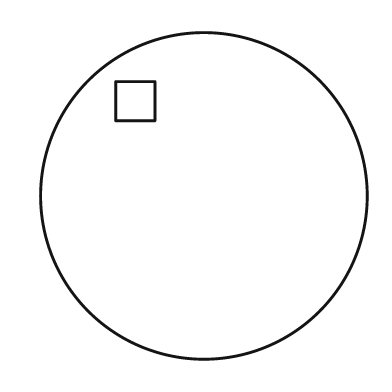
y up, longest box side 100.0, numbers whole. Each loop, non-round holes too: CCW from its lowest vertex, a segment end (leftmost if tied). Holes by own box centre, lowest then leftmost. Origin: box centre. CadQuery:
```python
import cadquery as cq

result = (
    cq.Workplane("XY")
    .moveTo(0.0, 0.0)
    .circle(50.0)
    .moveTo(-27.0, 23.0)
    .lineTo(-15.0, 23.0)
    .lineTo(-15.0, 35.0)
    .lineTo(-27.0, 35.0)
    .close()
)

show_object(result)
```